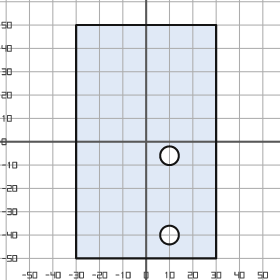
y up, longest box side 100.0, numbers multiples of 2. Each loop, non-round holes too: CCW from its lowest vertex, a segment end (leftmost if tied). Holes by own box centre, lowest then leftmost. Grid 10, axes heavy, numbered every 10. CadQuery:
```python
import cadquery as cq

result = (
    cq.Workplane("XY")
    .moveTo(-30.0, -50.0)
    .lineTo(30.0, -50.0)
    .lineTo(30.0, 50.0)
    .lineTo(-30.0, 50.0)
    .close()
    .moveTo(10.0, -40.0)
    .circle(4.0)
    .moveTo(10.0, -6.0)
    .circle(4.0)
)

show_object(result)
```